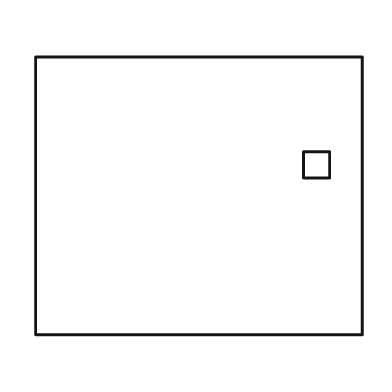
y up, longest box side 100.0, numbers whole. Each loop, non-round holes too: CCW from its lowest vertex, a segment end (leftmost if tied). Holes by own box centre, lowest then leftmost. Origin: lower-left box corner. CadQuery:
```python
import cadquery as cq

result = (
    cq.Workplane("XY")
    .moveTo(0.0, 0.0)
    .lineTo(100.0, 0.0)
    .lineTo(100.0, 85.0)
    .lineTo(0.0, 85.0)
    .close()
    .moveTo(82.0, 48.0)
    .lineTo(90.0, 48.0)
    .lineTo(90.0, 56.0)
    .lineTo(82.0, 56.0)
    .close()
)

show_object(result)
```